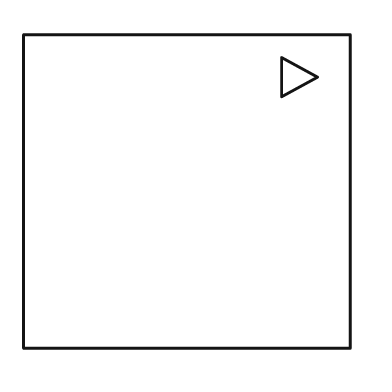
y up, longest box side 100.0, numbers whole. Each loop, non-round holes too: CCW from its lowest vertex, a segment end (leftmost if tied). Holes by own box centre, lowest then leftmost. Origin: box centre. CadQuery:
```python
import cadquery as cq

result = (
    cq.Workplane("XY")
    .moveTo(-50.0, -48.0)
    .lineTo(50.0, -48.0)
    .lineTo(50.0, 48.0)
    .lineTo(-50.0, 48.0)
    .close()
    .moveTo(29.0, 29.0)
    .lineTo(40.0, 35.0)
    .lineTo(29.0, 41.0)
    .close()
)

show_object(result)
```